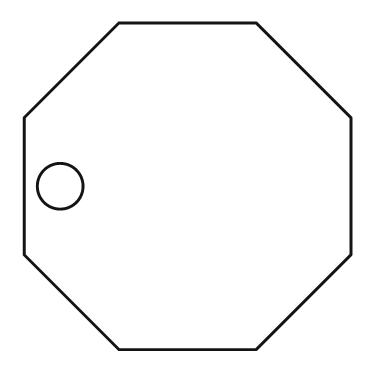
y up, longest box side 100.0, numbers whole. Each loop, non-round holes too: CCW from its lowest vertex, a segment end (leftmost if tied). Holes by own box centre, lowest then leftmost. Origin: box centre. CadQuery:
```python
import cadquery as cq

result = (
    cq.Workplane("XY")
    .moveTo(-21.0, -50.0)
    .lineTo(21.0, -50.0)
    .lineTo(50.0, -21.0)
    .lineTo(50.0, 21.0)
    .lineTo(21.0, 50.0)
    .lineTo(-21.0, 50.0)
    .lineTo(-50.0, 21.0)
    .lineTo(-50.0, -21.0)
    .close()
    .moveTo(-39.0, 0.0)
    .circle(7.0)
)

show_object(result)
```